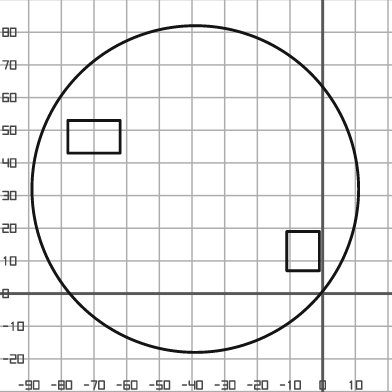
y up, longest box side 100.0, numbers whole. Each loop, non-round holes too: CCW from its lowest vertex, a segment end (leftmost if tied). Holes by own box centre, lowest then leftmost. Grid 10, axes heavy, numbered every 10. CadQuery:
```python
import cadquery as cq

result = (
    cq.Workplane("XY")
    .moveTo(-39.0, 32.0)
    .circle(50.0)
    .moveTo(-11.0, 7.0)
    .lineTo(-1.0, 7.0)
    .lineTo(-1.0, 19.0)
    .lineTo(-11.0, 19.0)
    .close()
    .moveTo(-78.0, 43.0)
    .lineTo(-62.0, 43.0)
    .lineTo(-62.0, 53.0)
    .lineTo(-78.0, 53.0)
    .close()
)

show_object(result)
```